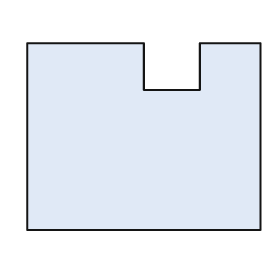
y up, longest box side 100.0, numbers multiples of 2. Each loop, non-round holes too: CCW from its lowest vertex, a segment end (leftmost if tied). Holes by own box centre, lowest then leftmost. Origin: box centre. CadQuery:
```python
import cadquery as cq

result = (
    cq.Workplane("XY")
    .moveTo(-50.0, -40.0)
    .lineTo(50.0, -40.0)
    .lineTo(50.0, 40.0)
    .lineTo(24.0, 40.0)
    .lineTo(24.0, 20.0)
    .lineTo(0.0, 20.0)
    .lineTo(0.0, 40.0)
    .lineTo(-50.0, 40.0)
    .close()
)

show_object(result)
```